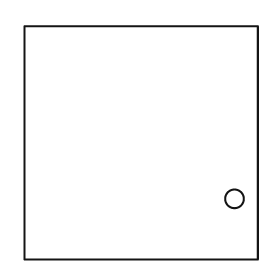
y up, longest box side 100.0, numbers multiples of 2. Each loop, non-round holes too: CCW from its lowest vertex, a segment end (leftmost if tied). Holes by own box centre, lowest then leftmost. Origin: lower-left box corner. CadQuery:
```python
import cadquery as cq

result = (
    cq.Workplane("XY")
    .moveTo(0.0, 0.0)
    .lineTo(100.0, 0.0)
    .lineTo(100.0, 100.0)
    .lineTo(0.0, 100.0)
    .close()
    .moveTo(90.0, 26.0)
    .circle(4.0)
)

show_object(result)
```